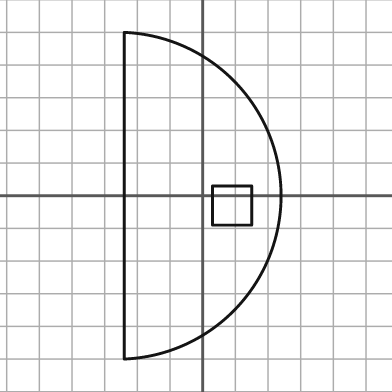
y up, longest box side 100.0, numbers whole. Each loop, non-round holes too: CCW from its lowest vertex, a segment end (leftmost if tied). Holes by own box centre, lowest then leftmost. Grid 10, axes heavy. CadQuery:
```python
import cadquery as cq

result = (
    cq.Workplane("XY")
    .moveTo(-24.0, -50.0)
    .threePointArc((24.0, 0.0), (-24.0, 50.0))
    .close()
    .moveTo(3.0, -9.0)
    .lineTo(15.0, -9.0)
    .lineTo(15.0, 3.0)
    .lineTo(3.0, 3.0)
    .close()
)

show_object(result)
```